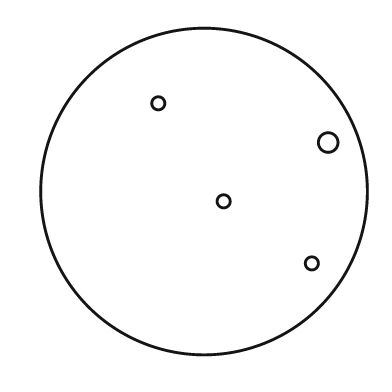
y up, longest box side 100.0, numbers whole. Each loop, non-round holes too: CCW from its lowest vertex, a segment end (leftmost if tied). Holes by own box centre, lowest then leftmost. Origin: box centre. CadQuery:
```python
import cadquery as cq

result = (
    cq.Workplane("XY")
    .moveTo(0.0, 0.0)
    .circle(50.0)
    .moveTo(33.0, -22.0)
    .circle(2.0)
    .moveTo(6.0, -3.0)
    .circle(2.0)
    .moveTo(38.0, 15.0)
    .circle(3.0)
    .moveTo(-14.0, 27.0)
    .circle(2.0)
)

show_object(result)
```